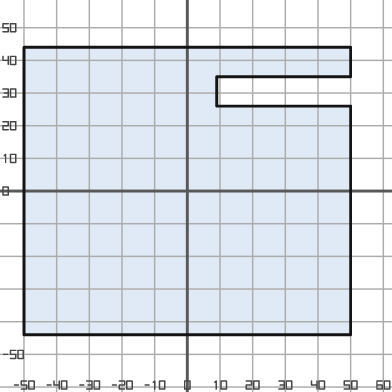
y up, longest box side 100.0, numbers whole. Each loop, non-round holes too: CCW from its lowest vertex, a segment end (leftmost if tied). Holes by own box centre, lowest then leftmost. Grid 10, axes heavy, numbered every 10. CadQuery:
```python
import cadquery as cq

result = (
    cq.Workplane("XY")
    .moveTo(-50.0, -44.0)
    .lineTo(50.0, -44.0)
    .lineTo(50.0, 26.0)
    .lineTo(9.0, 26.0)
    .lineTo(9.0, 35.0)
    .lineTo(50.0, 35.0)
    .lineTo(50.0, 44.0)
    .lineTo(-50.0, 44.0)
    .close()
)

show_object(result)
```